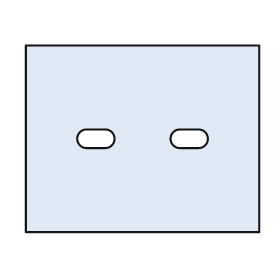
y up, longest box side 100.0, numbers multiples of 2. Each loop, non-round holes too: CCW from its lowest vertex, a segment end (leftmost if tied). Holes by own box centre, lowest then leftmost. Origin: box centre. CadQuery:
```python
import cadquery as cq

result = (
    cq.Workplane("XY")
    .moveTo(-50.0, -40.0)
    .lineTo(50.0, -40.0)
    .lineTo(50.0, 40.0)
    .lineTo(-50.0, 40.0)
    .close()
    .moveTo(-24.0, -4.0)
    .lineTo(-16.0, -4.0)
    .threePointArc((-12.0, 0.0), (-16.0, 4.0))
    .lineTo(-24.0, 4.0)
    .threePointArc((-28.0, 0.0), (-24.0, -4.0))
    .close()
    .moveTo(16.0, -4.0)
    .lineTo(24.0, -4.0)
    .threePointArc((28.0, 0.0), (24.0, 4.0))
    .lineTo(16.0, 4.0)
    .threePointArc((12.0, 0.0), (16.0, -4.0))
    .close()
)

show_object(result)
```